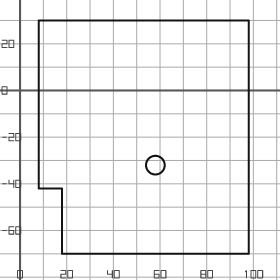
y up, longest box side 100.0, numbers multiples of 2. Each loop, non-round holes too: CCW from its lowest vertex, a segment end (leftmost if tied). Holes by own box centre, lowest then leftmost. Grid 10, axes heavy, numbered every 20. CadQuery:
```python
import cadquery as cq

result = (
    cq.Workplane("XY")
    .moveTo(18.0, -70.0)
    .lineTo(98.0, -70.0)
    .lineTo(98.0, 30.0)
    .lineTo(8.0, 30.0)
    .lineTo(8.0, -42.0)
    .lineTo(18.0, -42.0)
    .close()
    .moveTo(58.0, -32.0)
    .circle(4.0)
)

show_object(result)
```